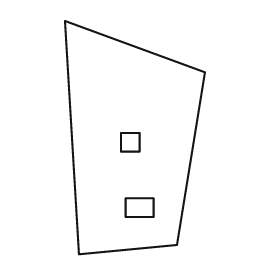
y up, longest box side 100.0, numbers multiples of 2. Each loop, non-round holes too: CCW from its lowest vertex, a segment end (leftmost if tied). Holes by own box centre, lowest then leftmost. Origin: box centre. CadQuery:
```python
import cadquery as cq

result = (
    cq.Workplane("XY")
    .moveTo(-24.0, -50.0)
    .lineTo(18.0, -46.0)
    .lineTo(30.0, 28.0)
    .lineTo(-30.0, 50.0)
    .close()
    .moveTo(-4.0, -34.0)
    .lineTo(8.0, -34.0)
    .lineTo(8.0, -26.0)
    .lineTo(-4.0, -26.0)
    .close()
    .moveTo(-6.0, -6.0)
    .lineTo(2.0, -6.0)
    .lineTo(2.0, 2.0)
    .lineTo(-6.0, 2.0)
    .close()
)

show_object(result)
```